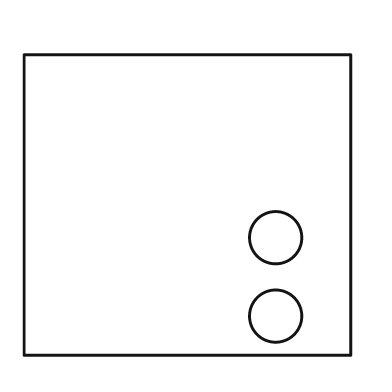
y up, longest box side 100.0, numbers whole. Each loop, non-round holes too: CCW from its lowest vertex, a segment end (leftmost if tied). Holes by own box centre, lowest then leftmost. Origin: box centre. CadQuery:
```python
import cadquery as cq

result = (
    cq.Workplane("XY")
    .moveTo(-50.0, -46.0)
    .lineTo(50.0, -46.0)
    .lineTo(50.0, 46.0)
    .lineTo(-50.0, 46.0)
    .close()
    .moveTo(27.0, -34.0)
    .circle(8.0)
    .moveTo(27.0, -10.0)
    .circle(8.0)
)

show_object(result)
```